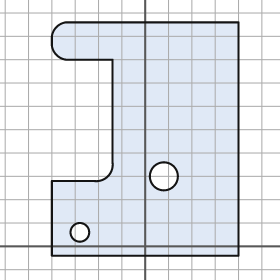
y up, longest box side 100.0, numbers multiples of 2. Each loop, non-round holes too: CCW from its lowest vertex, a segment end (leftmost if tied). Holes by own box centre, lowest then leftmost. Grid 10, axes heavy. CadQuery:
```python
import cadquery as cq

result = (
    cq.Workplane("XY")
    .moveTo(-40.0, -4.0)
    .lineTo(40.0, -4.0)
    .lineTo(40.0, 96.0)
    .lineTo(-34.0, 96.0)
    .threePointArc((-38.0, 94.0), (-40.0, 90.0))
    .lineTo(-40.0, 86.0)
    .threePointArc((-38.0, 82.0), (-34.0, 80.0))
    .lineTo(-14.0, 80.0)
    .lineTo(-14.0, 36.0)
    .threePointArc((-16.0, 30.0), (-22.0, 28.0))
    .lineTo(-40.0, 28.0)
    .close()
    .moveTo(-28.0, 6.0)
    .circle(4.0)
    .moveTo(8.0, 30.0)
    .circle(6.0)
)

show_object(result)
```